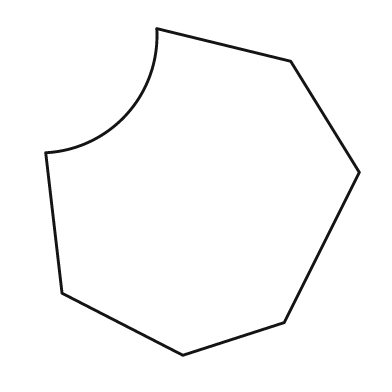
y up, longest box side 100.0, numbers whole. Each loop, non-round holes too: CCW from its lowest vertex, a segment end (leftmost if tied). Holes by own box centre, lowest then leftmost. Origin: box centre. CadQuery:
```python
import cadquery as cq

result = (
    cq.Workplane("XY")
    .moveTo(-6.0, -50.0)
    .lineTo(25.0, -40.0)
    .lineTo(48.0, 6.0)
    .lineTo(27.0, 40.0)
    .lineTo(-14.0, 50.0)
    .threePointArc((-23.0, 24.0), (-48.0, 12.0))
    .lineTo(-43.0, -31.0)
    .close()
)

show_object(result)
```